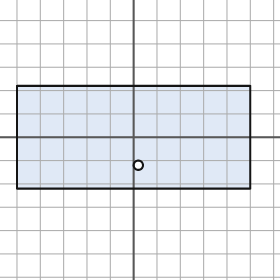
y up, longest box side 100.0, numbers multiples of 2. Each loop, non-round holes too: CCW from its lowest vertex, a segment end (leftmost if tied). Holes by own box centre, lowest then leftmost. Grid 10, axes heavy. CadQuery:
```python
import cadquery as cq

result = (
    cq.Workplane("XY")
    .moveTo(-50.0, -22.0)
    .lineTo(50.0, -22.0)
    .lineTo(50.0, 22.0)
    .lineTo(-50.0, 22.0)
    .close()
    .moveTo(2.0, -12.0)
    .circle(2.0)
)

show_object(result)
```